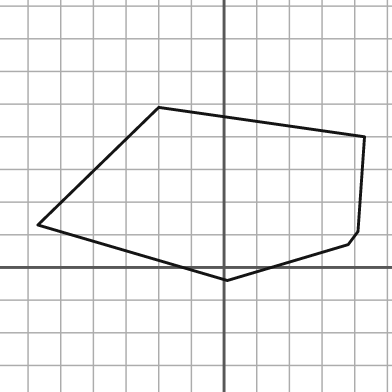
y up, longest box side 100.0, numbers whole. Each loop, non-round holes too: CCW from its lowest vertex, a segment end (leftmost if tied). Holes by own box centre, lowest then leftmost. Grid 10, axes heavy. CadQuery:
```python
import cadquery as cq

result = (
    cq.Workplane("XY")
    .moveTo(1.0, -4.0)
    .lineTo(38.0, 7.0)
    .lineTo(41.0, 11.0)
    .lineTo(43.0, 40.0)
    .lineTo(-20.0, 49.0)
    .lineTo(-57.0, 13.0)
    .close()
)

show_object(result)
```